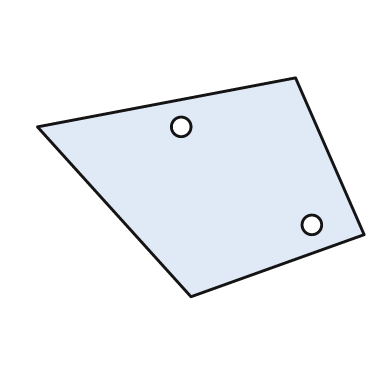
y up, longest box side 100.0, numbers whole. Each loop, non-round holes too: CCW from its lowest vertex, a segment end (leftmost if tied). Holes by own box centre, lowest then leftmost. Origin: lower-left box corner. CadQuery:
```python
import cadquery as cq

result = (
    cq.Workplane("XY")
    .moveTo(47.0, 0.0)
    .lineTo(100.0, 19.0)
    .lineTo(79.0, 67.0)
    .lineTo(0.0, 52.0)
    .close()
    .moveTo(84.0, 22.0)
    .circle(3.0)
    .moveTo(44.0, 52.0)
    .circle(3.0)
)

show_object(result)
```